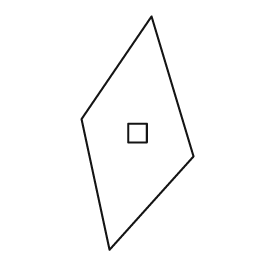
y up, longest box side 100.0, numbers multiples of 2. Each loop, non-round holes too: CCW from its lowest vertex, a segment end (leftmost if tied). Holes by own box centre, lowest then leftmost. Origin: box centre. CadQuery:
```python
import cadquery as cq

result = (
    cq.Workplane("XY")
    .moveTo(-12.0, -50.0)
    .lineTo(24.0, -10.0)
    .lineTo(6.0, 50.0)
    .lineTo(-24.0, 6.0)
    .close()
    .moveTo(-4.0, -4.0)
    .lineTo(4.0, -4.0)
    .lineTo(4.0, 4.0)
    .lineTo(-4.0, 4.0)
    .close()
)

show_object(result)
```